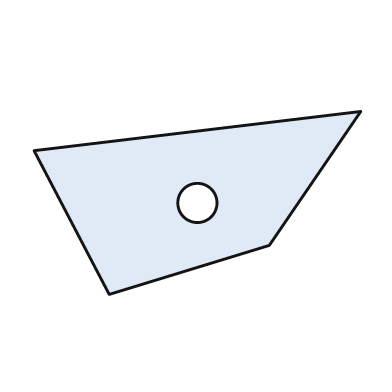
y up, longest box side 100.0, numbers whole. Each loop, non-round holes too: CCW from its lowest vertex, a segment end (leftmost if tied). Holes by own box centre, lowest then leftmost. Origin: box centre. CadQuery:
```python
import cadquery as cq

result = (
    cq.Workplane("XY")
    .moveTo(-27.0, -28.0)
    .lineTo(22.0, -13.0)
    .lineTo(50.0, 28.0)
    .lineTo(-50.0, 16.0)
    .close()
    .moveTo(0.0, 0.0)
    .circle(6.0)
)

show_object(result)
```